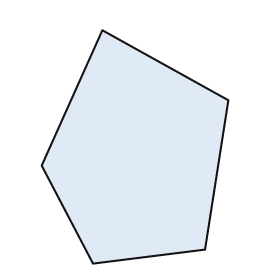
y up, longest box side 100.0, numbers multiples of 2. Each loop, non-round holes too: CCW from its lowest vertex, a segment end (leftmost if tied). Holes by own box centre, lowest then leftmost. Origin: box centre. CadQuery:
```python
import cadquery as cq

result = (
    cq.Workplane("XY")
    .moveTo(-18.0, -50.0)
    .lineTo(30.0, -44.0)
    .lineTo(40.0, 20.0)
    .lineTo(-14.0, 50.0)
    .lineTo(-40.0, -8.0)
    .close()
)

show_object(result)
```